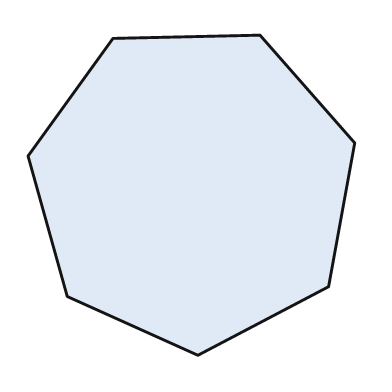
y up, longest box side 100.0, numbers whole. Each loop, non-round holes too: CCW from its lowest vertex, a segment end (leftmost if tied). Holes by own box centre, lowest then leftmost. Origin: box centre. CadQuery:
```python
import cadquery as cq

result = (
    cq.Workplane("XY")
    .moveTo(2.0, -49.0)
    .lineTo(42.0, -28.0)
    .lineTo(50.0, 16.0)
    .lineTo(21.0, 49.0)
    .lineTo(-24.0, 48.0)
    .lineTo(-50.0, 12.0)
    .lineTo(-38.0, -31.0)
    .close()
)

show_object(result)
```